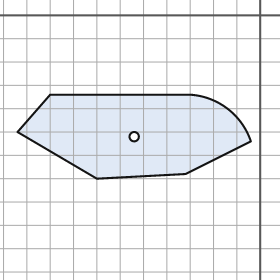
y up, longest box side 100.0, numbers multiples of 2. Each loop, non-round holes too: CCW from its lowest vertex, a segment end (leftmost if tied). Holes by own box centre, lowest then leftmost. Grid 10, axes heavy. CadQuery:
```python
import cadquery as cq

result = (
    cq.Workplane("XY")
    .moveTo(-70.0, -70.0)
    .lineTo(-32.0, -68.0)
    .lineTo(-4.0, -54.0)
    .threePointArc((-14.0, -40.0), (-30.0, -34.0))
    .lineTo(-90.0, -34.0)
    .lineTo(-104.0, -50.0)
    .close()
    .moveTo(-54.0, -52.0)
    .circle(2.0)
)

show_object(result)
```